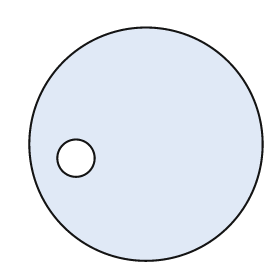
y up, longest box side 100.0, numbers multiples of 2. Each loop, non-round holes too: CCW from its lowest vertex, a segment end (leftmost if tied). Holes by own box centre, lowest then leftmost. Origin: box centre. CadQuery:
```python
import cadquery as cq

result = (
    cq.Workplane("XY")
    .moveTo(0.0, 0.0)
    .circle(50.0)
    .moveTo(-30.0, -6.0)
    .circle(8.0)
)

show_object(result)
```